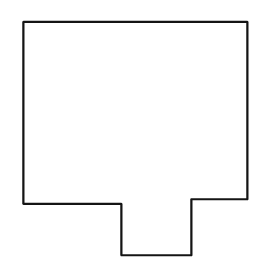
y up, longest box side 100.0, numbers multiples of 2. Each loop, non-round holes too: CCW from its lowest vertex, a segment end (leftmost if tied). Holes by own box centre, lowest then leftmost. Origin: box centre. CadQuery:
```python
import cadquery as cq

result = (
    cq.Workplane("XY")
    .moveTo(-6.0, -50.0)
    .lineTo(24.0, -50.0)
    .lineTo(24.0, -26.0)
    .lineTo(48.0, -26.0)
    .lineTo(48.0, 50.0)
    .lineTo(-48.0, 50.0)
    .lineTo(-48.0, -28.0)
    .lineTo(-6.0, -28.0)
    .close()
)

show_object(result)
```